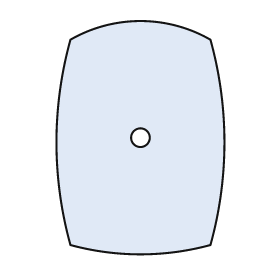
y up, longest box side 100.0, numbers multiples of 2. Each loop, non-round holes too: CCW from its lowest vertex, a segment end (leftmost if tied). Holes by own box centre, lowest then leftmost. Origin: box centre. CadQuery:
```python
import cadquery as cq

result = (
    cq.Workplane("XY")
    .moveTo(-30.0, -46.0)
    .threePointArc((0.0, -50.0), (30.0, -46.0))
    .threePointArc((36.0, -2.0), (30.0, 42.0))
    .threePointArc((0.0, 50.0), (-30.0, 42.0))
    .threePointArc((-36.0, -2.0), (-30.0, -46.0))
    .close()
    .moveTo(0.0, 0.0)
    .circle(4.0)
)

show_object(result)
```